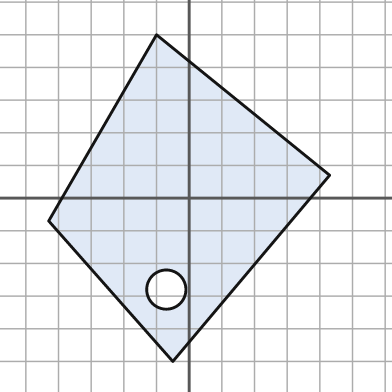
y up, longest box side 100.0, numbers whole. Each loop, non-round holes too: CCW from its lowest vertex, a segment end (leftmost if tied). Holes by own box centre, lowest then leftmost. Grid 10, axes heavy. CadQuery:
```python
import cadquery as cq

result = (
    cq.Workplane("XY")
    .moveTo(-5.0, -50.0)
    .lineTo(43.0, 7.0)
    .lineTo(-10.0, 50.0)
    .lineTo(-43.0, -7.0)
    .close()
    .moveTo(-7.0, -28.0)
    .circle(6.0)
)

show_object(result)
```